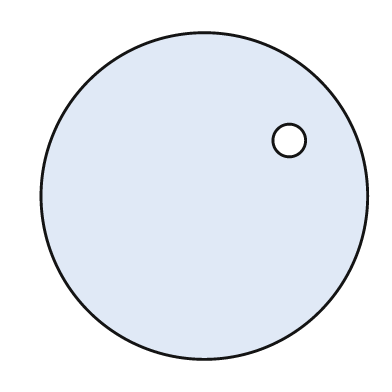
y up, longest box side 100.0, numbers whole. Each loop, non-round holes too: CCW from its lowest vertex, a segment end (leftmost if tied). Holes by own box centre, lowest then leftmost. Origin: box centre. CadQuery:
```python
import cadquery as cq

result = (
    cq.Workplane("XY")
    .moveTo(0.0, 0.0)
    .circle(50.0)
    .moveTo(26.0, 17.0)
    .circle(5.0)
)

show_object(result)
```